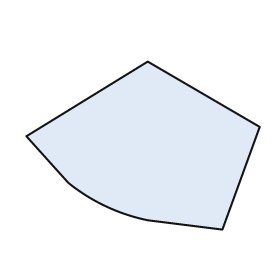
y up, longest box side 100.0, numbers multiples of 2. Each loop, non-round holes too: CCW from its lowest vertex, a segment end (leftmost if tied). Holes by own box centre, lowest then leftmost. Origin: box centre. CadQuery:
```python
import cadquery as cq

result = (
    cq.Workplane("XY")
    .moveTo(34.0, -36.0)
    .lineTo(50.0, 8.0)
    .lineTo(2.0, 36.0)
    .lineTo(-50.0, 4.0)
    .lineTo(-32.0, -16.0)
    .threePointArc((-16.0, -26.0), (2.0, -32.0))
    .close()
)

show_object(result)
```